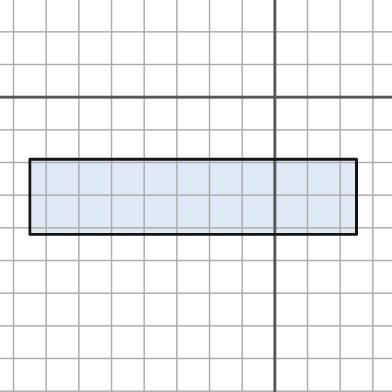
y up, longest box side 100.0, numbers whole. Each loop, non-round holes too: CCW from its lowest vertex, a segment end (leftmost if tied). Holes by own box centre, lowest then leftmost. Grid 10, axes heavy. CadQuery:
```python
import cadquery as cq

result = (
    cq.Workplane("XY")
    .moveTo(-75.0, -42.0)
    .lineTo(25.0, -42.0)
    .lineTo(25.0, -19.0)
    .lineTo(-75.0, -19.0)
    .close()
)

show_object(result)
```